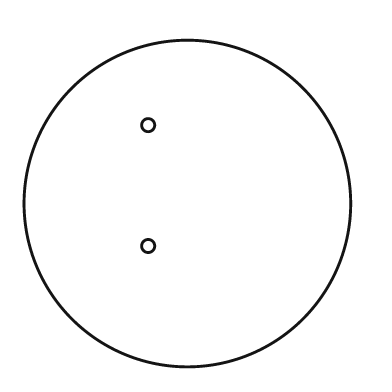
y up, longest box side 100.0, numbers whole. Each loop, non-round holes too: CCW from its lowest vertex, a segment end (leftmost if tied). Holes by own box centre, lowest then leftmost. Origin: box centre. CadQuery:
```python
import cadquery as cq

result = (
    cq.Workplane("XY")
    .moveTo(0.0, 0.0)
    .circle(50.0)
    .moveTo(-12.0, -13.0)
    .circle(2.0)
    .moveTo(-12.0, 24.0)
    .circle(2.0)
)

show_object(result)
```